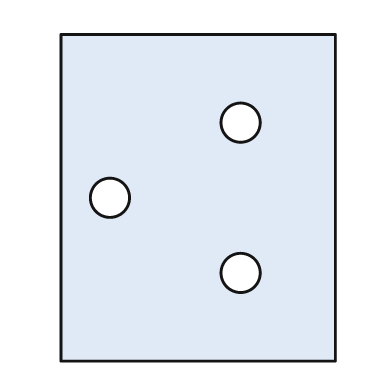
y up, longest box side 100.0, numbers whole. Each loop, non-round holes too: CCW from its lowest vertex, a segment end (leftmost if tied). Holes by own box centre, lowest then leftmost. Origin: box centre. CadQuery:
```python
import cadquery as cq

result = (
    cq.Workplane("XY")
    .moveTo(-42.0, -50.0)
    .lineTo(42.0, -50.0)
    .lineTo(42.0, 50.0)
    .lineTo(-42.0, 50.0)
    .close()
    .moveTo(13.0, -23.0)
    .circle(6.0)
    .moveTo(-27.0, 0.0)
    .circle(6.0)
    .moveTo(13.0, 23.0)
    .circle(6.0)
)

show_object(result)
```